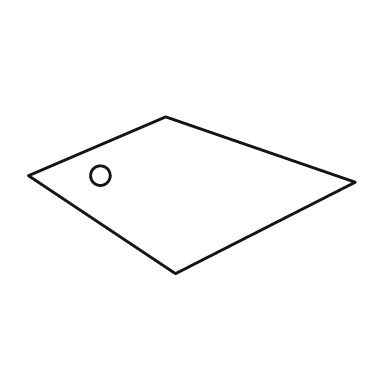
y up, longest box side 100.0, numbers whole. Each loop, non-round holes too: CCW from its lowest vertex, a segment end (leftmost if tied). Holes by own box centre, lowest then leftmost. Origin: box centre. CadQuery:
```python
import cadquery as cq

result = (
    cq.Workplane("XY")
    .moveTo(-5.0, -24.0)
    .lineTo(50.0, 4.0)
    .lineTo(-8.0, 24.0)
    .lineTo(-50.0, 6.0)
    .close()
    .moveTo(-28.0, 6.0)
    .circle(3.0)
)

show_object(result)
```